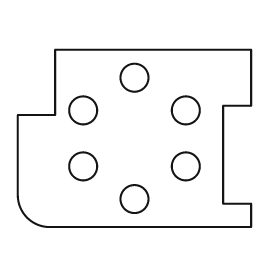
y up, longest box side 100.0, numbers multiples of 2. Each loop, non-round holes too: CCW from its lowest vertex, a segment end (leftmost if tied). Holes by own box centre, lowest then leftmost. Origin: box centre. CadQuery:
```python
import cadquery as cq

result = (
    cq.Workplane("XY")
    .moveTo(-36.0, -38.0)
    .lineTo(50.0, -38.0)
    .lineTo(50.0, -28.0)
    .lineTo(38.0, -28.0)
    .lineTo(38.0, 14.0)
    .lineTo(50.0, 14.0)
    .lineTo(50.0, 38.0)
    .lineTo(-34.0, 38.0)
    .lineTo(-34.0, 10.0)
    .lineTo(-50.0, 10.0)
    .lineTo(-50.0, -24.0)
    .threePointArc((-46.0, -34.0), (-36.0, -38.0))
    .close()
    .moveTo(0.0, -26.0)
    .circle(6.0)
    .moveTo(-22.0, -12.0)
    .circle(6.0)
    .moveTo(22.0, -12.0)
    .circle(6.0)
    .moveTo(-22.0, 12.0)
    .circle(6.0)
    .moveTo(22.0, 12.0)
    .circle(6.0)
    .moveTo(0.0, 26.0)
    .circle(6.0)
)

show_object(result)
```